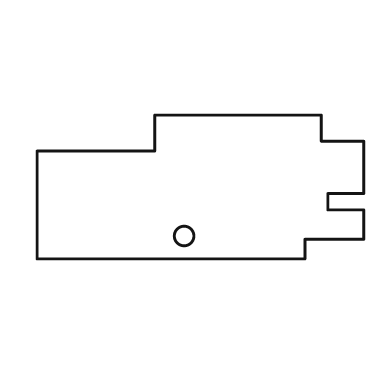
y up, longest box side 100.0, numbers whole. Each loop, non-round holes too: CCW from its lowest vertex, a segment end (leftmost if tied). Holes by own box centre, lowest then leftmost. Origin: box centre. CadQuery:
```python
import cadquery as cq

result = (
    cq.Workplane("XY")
    .moveTo(-50.0, -22.0)
    .lineTo(32.0, -22.0)
    .lineTo(32.0, -16.0)
    .lineTo(50.0, -16.0)
    .lineTo(50.0, -7.0)
    .lineTo(39.0, -7.0)
    .lineTo(39.0, -2.0)
    .lineTo(50.0, -2.0)
    .lineTo(50.0, 14.0)
    .lineTo(37.0, 14.0)
    .lineTo(37.0, 22.0)
    .lineTo(-14.0, 22.0)
    .lineTo(-14.0, 11.0)
    .lineTo(-50.0, 11.0)
    .close()
    .moveTo(-5.0, -15.0)
    .circle(3.0)
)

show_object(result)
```